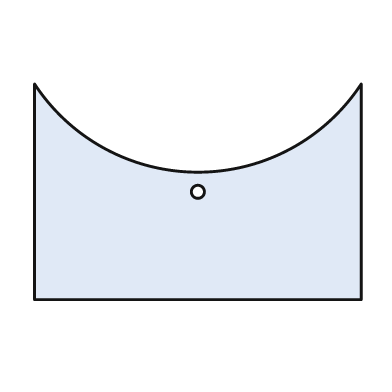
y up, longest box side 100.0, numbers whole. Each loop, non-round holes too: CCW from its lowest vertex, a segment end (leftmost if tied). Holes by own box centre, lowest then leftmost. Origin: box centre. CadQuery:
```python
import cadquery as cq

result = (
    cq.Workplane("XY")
    .moveTo(-50.0, -33.0)
    .lineTo(50.0, -33.0)
    .lineTo(50.0, 33.0)
    .threePointArc((0.0, 6.0), (-50.0, 33.0))
    .close()
    .moveTo(0.0, 0.0)
    .circle(2.0)
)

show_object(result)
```